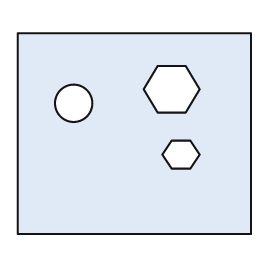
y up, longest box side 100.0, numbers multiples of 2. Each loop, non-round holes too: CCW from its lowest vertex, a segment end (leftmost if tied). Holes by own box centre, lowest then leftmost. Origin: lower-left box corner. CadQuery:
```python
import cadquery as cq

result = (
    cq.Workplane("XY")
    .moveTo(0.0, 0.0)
    .lineTo(100.0, 0.0)
    .lineTo(100.0, 86.0)
    .lineTo(0.0, 86.0)
    .close()
    .moveTo(66.0, 28.0)
    .lineTo(74.0, 28.0)
    .lineTo(78.0, 34.0)
    .lineTo(74.0, 40.0)
    .lineTo(66.0, 40.0)
    .lineTo(62.0, 34.0)
    .close()
    .moveTo(24.0, 56.0)
    .circle(8.0)
    .moveTo(60.0, 52.0)
    .lineTo(72.0, 52.0)
    .lineTo(78.0, 62.0)
    .lineTo(72.0, 72.0)
    .lineTo(60.0, 72.0)
    .lineTo(54.0, 62.0)
    .close()
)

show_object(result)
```